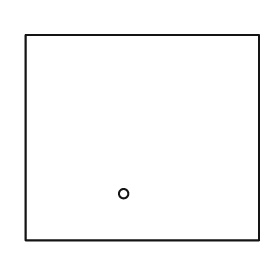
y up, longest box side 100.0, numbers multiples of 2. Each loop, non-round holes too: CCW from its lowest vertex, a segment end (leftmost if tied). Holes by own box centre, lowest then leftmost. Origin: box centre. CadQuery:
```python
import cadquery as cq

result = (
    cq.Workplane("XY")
    .moveTo(-50.0, -44.0)
    .lineTo(50.0, -44.0)
    .lineTo(50.0, 44.0)
    .lineTo(-50.0, 44.0)
    .close()
    .moveTo(-8.0, -24.0)
    .circle(2.0)
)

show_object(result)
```